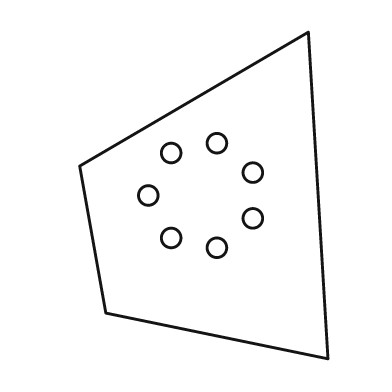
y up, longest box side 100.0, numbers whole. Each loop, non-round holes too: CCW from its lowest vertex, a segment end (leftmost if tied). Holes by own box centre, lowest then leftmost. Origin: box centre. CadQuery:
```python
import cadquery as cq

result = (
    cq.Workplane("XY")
    .moveTo(38.0, -50.0)
    .lineTo(32.0, 50.0)
    .lineTo(-38.0, 9.0)
    .lineTo(-30.0, -36.0)
    .close()
    .moveTo(4.0, -16.0)
    .circle(3.0)
    .moveTo(-10.0, -13.0)
    .circle(3.0)
    .moveTo(15.0, -7.0)
    .circle(3.0)
    .moveTo(-17.0, 0.0)
    .circle(3.0)
    .moveTo(15.0, 7.0)
    .circle(3.0)
    .moveTo(-10.0, 13.0)
    .circle(3.0)
    .moveTo(4.0, 16.0)
    .circle(3.0)
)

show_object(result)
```